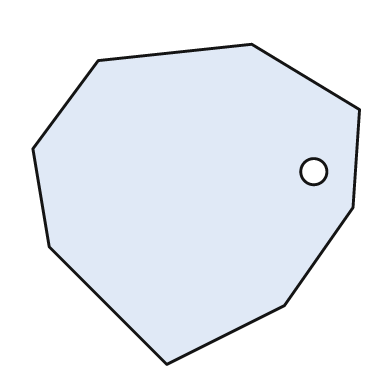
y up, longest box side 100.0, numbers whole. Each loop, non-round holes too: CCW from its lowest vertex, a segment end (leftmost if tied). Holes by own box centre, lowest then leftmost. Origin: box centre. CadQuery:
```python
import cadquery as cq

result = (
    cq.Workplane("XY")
    .moveTo(-9.0, -49.0)
    .lineTo(27.0, -31.0)
    .lineTo(48.0, -1.0)
    .lineTo(50.0, 29.0)
    .lineTo(17.0, 49.0)
    .lineTo(-30.0, 44.0)
    .lineTo(-50.0, 17.0)
    .lineTo(-45.0, -13.0)
    .close()
    .moveTo(36.0, 10.0)
    .circle(4.0)
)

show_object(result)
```